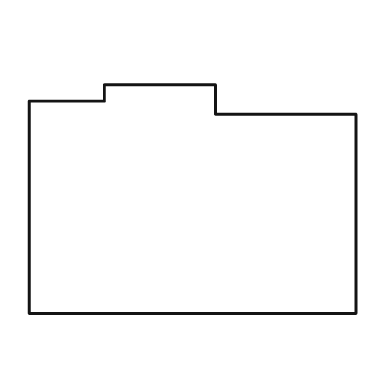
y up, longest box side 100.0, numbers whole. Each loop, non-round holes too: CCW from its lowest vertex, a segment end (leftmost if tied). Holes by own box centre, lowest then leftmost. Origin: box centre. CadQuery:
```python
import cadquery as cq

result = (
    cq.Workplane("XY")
    .moveTo(-50.0, -35.0)
    .lineTo(50.0, -35.0)
    .lineTo(50.0, 26.0)
    .lineTo(7.0, 26.0)
    .lineTo(7.0, 35.0)
    .lineTo(-27.0, 35.0)
    .lineTo(-27.0, 30.0)
    .lineTo(-50.0, 30.0)
    .close()
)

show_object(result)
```